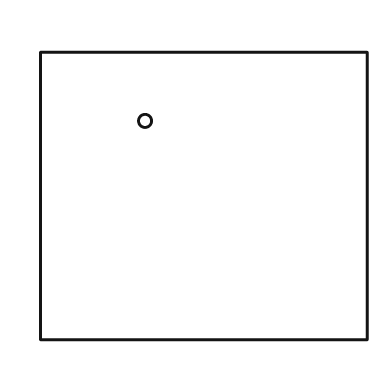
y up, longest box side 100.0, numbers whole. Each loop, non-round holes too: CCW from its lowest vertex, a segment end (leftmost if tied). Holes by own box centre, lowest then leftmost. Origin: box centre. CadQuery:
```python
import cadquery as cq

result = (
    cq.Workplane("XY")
    .moveTo(-50.0, -44.0)
    .lineTo(50.0, -44.0)
    .lineTo(50.0, 44.0)
    .lineTo(-50.0, 44.0)
    .close()
    .moveTo(-18.0, 23.0)
    .circle(2.0)
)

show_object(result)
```